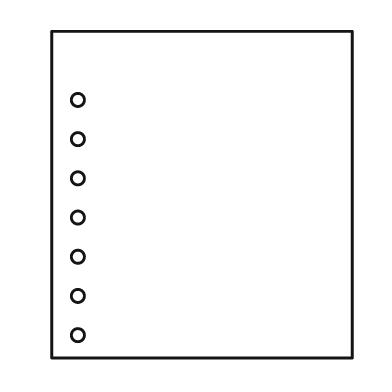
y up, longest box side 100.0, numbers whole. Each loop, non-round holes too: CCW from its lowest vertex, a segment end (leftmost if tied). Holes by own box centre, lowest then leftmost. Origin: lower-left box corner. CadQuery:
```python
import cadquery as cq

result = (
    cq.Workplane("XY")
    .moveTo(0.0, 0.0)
    .lineTo(92.0, 0.0)
    .lineTo(92.0, 100.0)
    .lineTo(0.0, 100.0)
    .close()
    .moveTo(8.0, 7.0)
    .circle(2.0)
    .moveTo(8.0, 19.0)
    .circle(2.0)
    .moveTo(8.0, 31.0)
    .circle(2.0)
    .moveTo(8.0, 43.0)
    .circle(2.0)
    .moveTo(8.0, 55.0)
    .circle(2.0)
    .moveTo(8.0, 67.0)
    .circle(2.0)
    .moveTo(8.0, 79.0)
    .circle(2.0)
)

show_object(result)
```